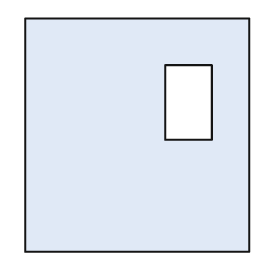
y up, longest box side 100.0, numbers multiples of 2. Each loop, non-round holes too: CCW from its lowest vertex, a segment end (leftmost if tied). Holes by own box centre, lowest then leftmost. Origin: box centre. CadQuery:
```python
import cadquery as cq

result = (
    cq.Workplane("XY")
    .moveTo(-48.0, -50.0)
    .lineTo(48.0, -50.0)
    .lineTo(48.0, 50.0)
    .lineTo(-48.0, 50.0)
    .close()
    .moveTo(12.0, -2.0)
    .lineTo(32.0, -2.0)
    .lineTo(32.0, 30.0)
    .lineTo(12.0, 30.0)
    .close()
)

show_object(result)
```